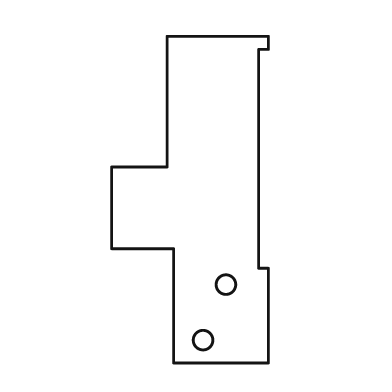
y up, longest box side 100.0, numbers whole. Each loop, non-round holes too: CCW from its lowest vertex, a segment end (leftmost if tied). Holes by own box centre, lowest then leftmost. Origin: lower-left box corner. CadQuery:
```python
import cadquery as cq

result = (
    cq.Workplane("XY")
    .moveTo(19.0, 0.0)
    .lineTo(48.0, 0.0)
    .lineTo(48.0, 29.0)
    .lineTo(45.0, 29.0)
    .lineTo(45.0, 96.0)
    .lineTo(48.0, 96.0)
    .lineTo(48.0, 100.0)
    .lineTo(17.0, 100.0)
    .lineTo(17.0, 60.0)
    .lineTo(0.0, 60.0)
    .lineTo(0.0, 35.0)
    .lineTo(19.0, 35.0)
    .close()
    .moveTo(28.0, 7.0)
    .circle(3.0)
    .moveTo(35.0, 24.0)
    .circle(3.0)
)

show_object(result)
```